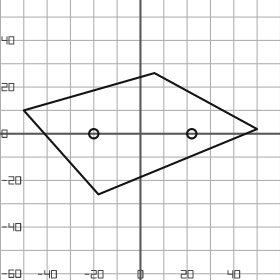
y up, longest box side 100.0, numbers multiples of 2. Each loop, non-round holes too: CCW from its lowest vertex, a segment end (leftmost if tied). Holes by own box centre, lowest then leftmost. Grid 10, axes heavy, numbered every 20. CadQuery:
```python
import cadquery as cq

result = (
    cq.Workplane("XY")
    .moveTo(-18.0, -26.0)
    .lineTo(50.0, 2.0)
    .lineTo(6.0, 26.0)
    .lineTo(-50.0, 10.0)
    .close()
    .moveTo(-20.0, 0.0)
    .circle(2.0)
    .moveTo(22.0, 0.0)
    .circle(2.0)
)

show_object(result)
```